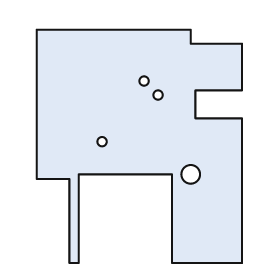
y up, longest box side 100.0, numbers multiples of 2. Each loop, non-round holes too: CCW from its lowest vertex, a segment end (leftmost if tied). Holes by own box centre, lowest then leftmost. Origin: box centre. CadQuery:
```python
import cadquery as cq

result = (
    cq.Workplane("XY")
    .moveTo(-30.0, -50.0)
    .lineTo(-26.0, -50.0)
    .lineTo(-26.0, -12.0)
    .lineTo(14.0, -12.0)
    .lineTo(14.0, -50.0)
    .lineTo(44.0, -50.0)
    .lineTo(44.0, 12.0)
    .lineTo(24.0, 12.0)
    .lineTo(24.0, 24.0)
    .lineTo(44.0, 24.0)
    .lineTo(44.0, 44.0)
    .lineTo(22.0, 44.0)
    .lineTo(22.0, 50.0)
    .lineTo(-44.0, 50.0)
    .lineTo(-44.0, -14.0)
    .lineTo(-30.0, -14.0)
    .close()
    .moveTo(22.0, -12.0)
    .circle(4.0)
    .moveTo(-16.0, 2.0)
    .circle(2.0)
    .moveTo(8.0, 22.0)
    .circle(2.0)
    .moveTo(2.0, 28.0)
    .circle(2.0)
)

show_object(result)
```